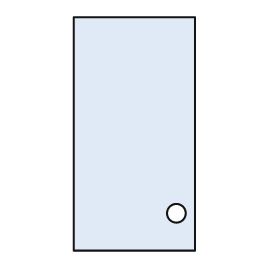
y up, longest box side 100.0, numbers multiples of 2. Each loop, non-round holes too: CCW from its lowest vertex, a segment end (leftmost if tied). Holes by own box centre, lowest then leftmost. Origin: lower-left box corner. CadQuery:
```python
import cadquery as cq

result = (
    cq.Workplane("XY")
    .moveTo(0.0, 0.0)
    .lineTo(52.0, 0.0)
    .lineTo(52.0, 100.0)
    .lineTo(0.0, 100.0)
    .close()
    .moveTo(44.0, 16.0)
    .circle(4.0)
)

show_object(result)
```